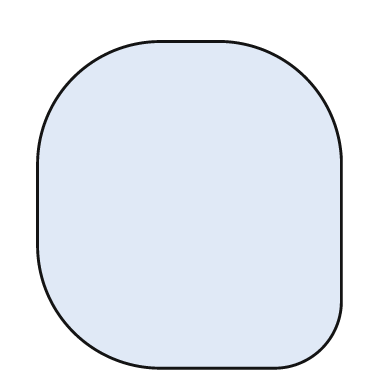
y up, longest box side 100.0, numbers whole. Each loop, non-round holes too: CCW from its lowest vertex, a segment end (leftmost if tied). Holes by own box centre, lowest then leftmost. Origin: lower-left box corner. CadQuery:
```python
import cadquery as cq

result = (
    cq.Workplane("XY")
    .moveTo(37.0, 0.0)
    .lineTo(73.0, 0.0)
    .threePointArc((87.0, 6.0), (93.0, 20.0))
    .lineTo(93.0, 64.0)
    .threePointArc((82.0, 89.0), (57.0, 100.0))
    .lineTo(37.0, 100.0)
    .threePointArc((11.0, 89.0), (0.0, 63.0))
    .lineTo(0.0, 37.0)
    .threePointArc((11.0, 11.0), (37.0, 0.0))
    .close()
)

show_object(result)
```